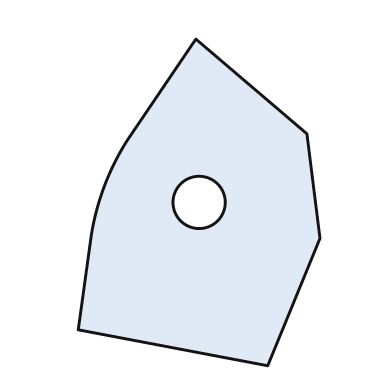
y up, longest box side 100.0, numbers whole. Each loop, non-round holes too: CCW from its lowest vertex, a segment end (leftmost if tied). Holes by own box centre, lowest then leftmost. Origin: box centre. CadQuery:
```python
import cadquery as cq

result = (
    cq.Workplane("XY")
    .moveTo(21.0, -50.0)
    .lineTo(37.0, -11.0)
    .lineTo(33.0, 21.0)
    .lineTo(-1.0, 50.0)
    .lineTo(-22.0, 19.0)
    .threePointArc((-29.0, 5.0), (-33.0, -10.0))
    .lineTo(-37.0, -39.0)
    .close()
    .moveTo(0.0, 0.0)
    .circle(8.0)
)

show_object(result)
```